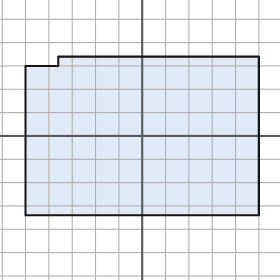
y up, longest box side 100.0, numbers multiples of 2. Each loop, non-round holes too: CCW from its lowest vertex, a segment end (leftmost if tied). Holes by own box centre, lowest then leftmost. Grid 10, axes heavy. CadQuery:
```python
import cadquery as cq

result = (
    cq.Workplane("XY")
    .moveTo(-50.0, -34.0)
    .lineTo(50.0, -34.0)
    .lineTo(50.0, 34.0)
    .lineTo(-36.0, 34.0)
    .lineTo(-36.0, 30.0)
    .lineTo(-50.0, 30.0)
    .close()
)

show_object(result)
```